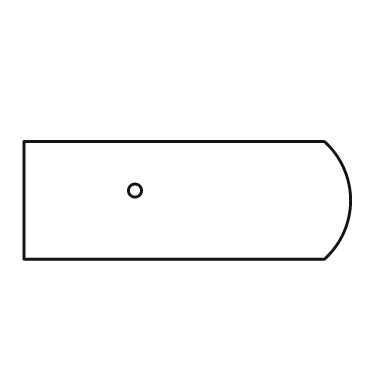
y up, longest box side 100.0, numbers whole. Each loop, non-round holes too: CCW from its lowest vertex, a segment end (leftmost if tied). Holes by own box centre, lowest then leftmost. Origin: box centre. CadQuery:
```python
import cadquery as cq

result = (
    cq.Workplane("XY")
    .moveTo(-50.0, -18.0)
    .lineTo(42.0, -18.0)
    .threePointArc((50.0, 0.0), (42.0, 18.0))
    .lineTo(-50.0, 18.0)
    .close()
    .moveTo(-16.0, 3.0)
    .circle(2.0)
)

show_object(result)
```